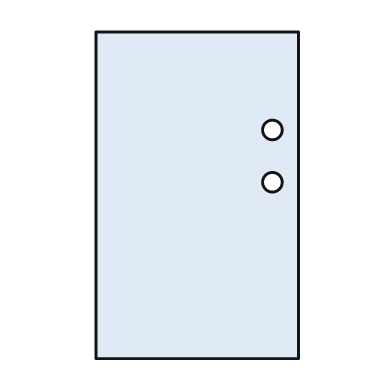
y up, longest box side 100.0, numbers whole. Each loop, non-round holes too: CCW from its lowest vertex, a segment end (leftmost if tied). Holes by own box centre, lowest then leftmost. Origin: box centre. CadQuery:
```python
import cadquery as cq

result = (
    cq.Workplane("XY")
    .moveTo(-31.0, -50.0)
    .lineTo(31.0, -50.0)
    .lineTo(31.0, 50.0)
    .lineTo(-31.0, 50.0)
    .close()
    .moveTo(23.0, 4.0)
    .circle(3.0)
    .moveTo(23.0, 20.0)
    .circle(3.0)
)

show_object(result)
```